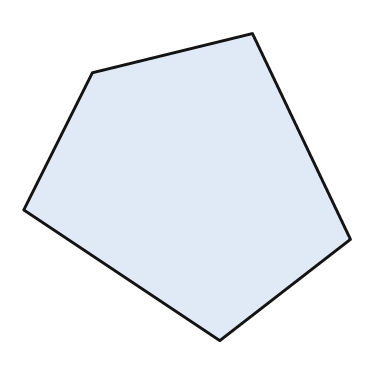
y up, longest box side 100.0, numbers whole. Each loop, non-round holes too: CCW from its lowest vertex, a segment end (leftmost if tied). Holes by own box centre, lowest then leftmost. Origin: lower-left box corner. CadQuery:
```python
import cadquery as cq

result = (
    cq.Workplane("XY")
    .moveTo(60.0, 0.0)
    .lineTo(100.0, 31.0)
    .lineTo(70.0, 94.0)
    .lineTo(21.0, 82.0)
    .lineTo(0.0, 40.0)
    .close()
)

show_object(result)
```